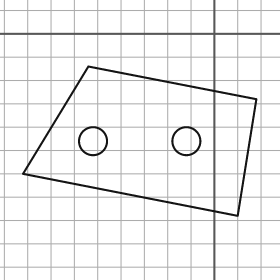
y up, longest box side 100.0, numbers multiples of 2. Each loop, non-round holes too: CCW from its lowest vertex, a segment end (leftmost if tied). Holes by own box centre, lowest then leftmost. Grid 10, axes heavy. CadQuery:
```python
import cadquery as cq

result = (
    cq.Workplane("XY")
    .moveTo(10.0, -78.0)
    .lineTo(18.0, -28.0)
    .lineTo(-54.0, -14.0)
    .lineTo(-82.0, -60.0)
    .close()
    .moveTo(-52.0, -46.0)
    .circle(6.0)
    .moveTo(-12.0, -46.0)
    .circle(6.0)
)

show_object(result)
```